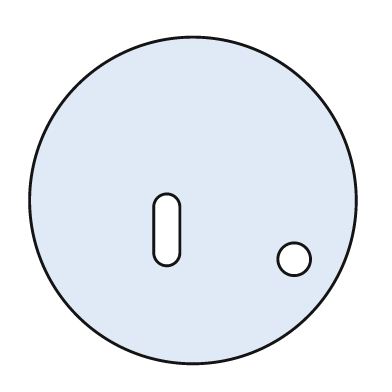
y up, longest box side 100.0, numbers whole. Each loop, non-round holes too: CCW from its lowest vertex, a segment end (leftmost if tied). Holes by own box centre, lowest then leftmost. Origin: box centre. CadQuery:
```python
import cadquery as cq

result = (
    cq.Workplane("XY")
    .moveTo(0.0, 0.0)
    .circle(50.0)
    .moveTo(31.0, -18.0)
    .circle(5.0)
    .moveTo(-12.0, -16.0)
    .threePointArc((-8.0, -20.0), (-4.0, -16.0))
    .lineTo(-4.0, -2.0)
    .threePointArc((-8.0, 2.0), (-12.0, -2.0))
    .close()
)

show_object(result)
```